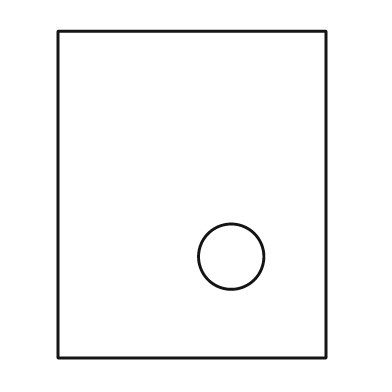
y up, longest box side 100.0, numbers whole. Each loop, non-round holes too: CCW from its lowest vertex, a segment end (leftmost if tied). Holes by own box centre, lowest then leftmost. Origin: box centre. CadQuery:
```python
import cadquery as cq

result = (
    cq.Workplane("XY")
    .moveTo(-41.0, -50.0)
    .lineTo(41.0, -50.0)
    .lineTo(41.0, 50.0)
    .lineTo(-41.0, 50.0)
    .close()
    .moveTo(12.0, -19.0)
    .circle(10.0)
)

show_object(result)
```